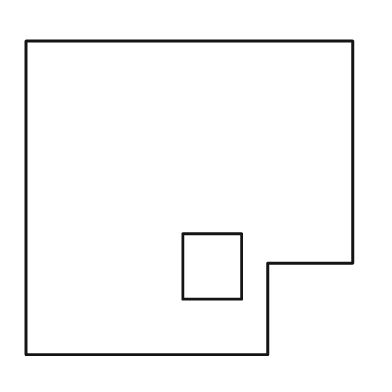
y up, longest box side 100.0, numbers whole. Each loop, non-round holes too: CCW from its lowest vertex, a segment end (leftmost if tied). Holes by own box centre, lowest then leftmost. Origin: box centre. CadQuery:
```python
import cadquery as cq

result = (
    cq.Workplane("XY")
    .moveTo(-50.0, -48.0)
    .lineTo(24.0, -48.0)
    .lineTo(24.0, -20.0)
    .lineTo(50.0, -20.0)
    .lineTo(50.0, 48.0)
    .lineTo(-50.0, 48.0)
    .close()
    .moveTo(-2.0, -31.0)
    .lineTo(16.0, -31.0)
    .lineTo(16.0, -11.0)
    .lineTo(-2.0, -11.0)
    .close()
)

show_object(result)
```